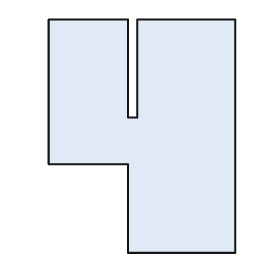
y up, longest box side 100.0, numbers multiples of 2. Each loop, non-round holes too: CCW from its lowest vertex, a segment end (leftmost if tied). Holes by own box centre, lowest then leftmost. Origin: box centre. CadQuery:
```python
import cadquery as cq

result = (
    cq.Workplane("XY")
    .moveTo(-6.0, -50.0)
    .lineTo(40.0, -50.0)
    .lineTo(40.0, 50.0)
    .lineTo(-2.0, 50.0)
    .lineTo(-2.0, 8.0)
    .lineTo(-6.0, 8.0)
    .lineTo(-6.0, 50.0)
    .lineTo(-40.0, 50.0)
    .lineTo(-40.0, -12.0)
    .lineTo(-6.0, -12.0)
    .close()
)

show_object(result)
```